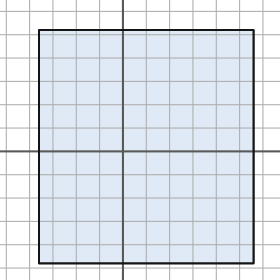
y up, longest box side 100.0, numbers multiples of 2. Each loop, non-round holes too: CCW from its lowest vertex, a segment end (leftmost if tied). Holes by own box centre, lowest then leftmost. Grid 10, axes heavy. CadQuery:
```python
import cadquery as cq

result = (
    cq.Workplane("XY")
    .moveTo(-36.0, -48.0)
    .lineTo(56.0, -48.0)
    .lineTo(56.0, 52.0)
    .lineTo(-36.0, 52.0)
    .close()
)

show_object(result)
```